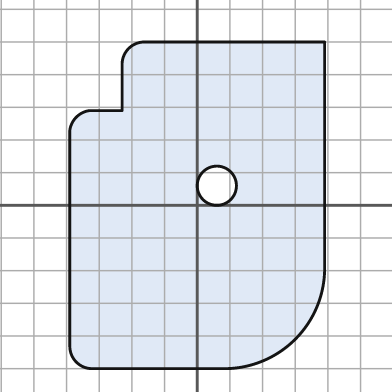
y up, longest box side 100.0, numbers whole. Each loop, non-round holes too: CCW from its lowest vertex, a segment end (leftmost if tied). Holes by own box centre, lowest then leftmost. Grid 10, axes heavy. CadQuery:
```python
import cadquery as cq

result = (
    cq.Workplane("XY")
    .moveTo(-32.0, -50.0)
    .lineTo(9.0, -50.0)
    .threePointArc((30.0, -41.0), (39.0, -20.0))
    .lineTo(39.0, 50.0)
    .lineTo(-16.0, 50.0)
    .threePointArc((-21.0, 48.0), (-23.0, 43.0))
    .lineTo(-23.0, 29.0)
    .lineTo(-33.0, 29.0)
    .threePointArc((-37.0, 27.0), (-39.0, 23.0))
    .lineTo(-39.0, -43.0)
    .threePointArc((-37.0, -48.0), (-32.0, -50.0))
    .close()
    .moveTo(6.0, 6.0)
    .circle(6.0)
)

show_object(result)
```